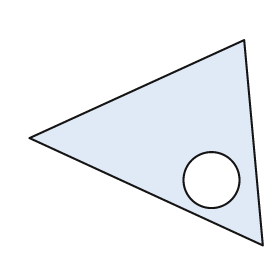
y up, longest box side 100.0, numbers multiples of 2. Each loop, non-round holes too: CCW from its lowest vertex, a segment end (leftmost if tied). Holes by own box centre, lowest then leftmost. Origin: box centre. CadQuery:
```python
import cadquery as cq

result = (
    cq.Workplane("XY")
    .moveTo(50.0, -44.0)
    .lineTo(42.0, 44.0)
    .lineTo(-50.0, 2.0)
    .close()
    .moveTo(28.0, -16.0)
    .circle(12.0)
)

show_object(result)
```